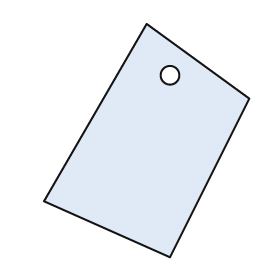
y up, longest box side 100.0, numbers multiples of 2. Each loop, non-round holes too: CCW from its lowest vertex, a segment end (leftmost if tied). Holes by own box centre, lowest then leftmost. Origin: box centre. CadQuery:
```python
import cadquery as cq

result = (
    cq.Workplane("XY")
    .moveTo(10.0, -50.0)
    .lineTo(44.0, 18.0)
    .lineTo(0.0, 50.0)
    .lineTo(-44.0, -26.0)
    .close()
    .moveTo(10.0, 28.0)
    .circle(4.0)
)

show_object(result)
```